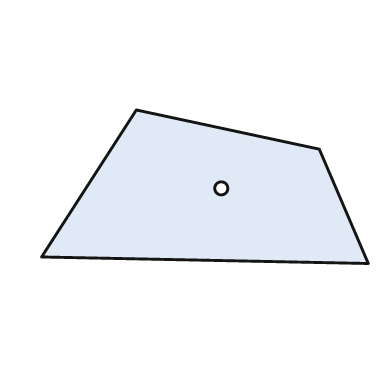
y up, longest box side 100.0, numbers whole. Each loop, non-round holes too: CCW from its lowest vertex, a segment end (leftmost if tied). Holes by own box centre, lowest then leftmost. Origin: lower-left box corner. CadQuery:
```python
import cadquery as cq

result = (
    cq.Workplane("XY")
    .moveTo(100.0, 0.0)
    .lineTo(85.0, 35.0)
    .lineTo(29.0, 47.0)
    .lineTo(0.0, 2.0)
    .close()
    .moveTo(55.0, 23.0)
    .circle(2.0)
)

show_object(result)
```